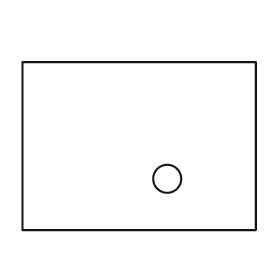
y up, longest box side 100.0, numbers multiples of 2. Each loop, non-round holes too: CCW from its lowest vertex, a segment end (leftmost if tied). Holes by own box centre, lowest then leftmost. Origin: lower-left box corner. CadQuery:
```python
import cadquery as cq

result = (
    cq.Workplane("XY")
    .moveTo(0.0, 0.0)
    .lineTo(100.0, 0.0)
    .lineTo(100.0, 72.0)
    .lineTo(0.0, 72.0)
    .close()
    .moveTo(62.0, 22.0)
    .circle(6.0)
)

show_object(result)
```